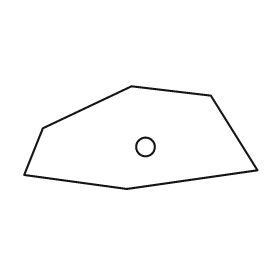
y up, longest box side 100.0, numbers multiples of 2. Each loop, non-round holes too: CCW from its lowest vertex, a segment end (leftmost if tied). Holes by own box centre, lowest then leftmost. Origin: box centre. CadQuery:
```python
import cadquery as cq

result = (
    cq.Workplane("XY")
    .moveTo(-6.0, -22.0)
    .lineTo(50.0, -14.0)
    .lineTo(30.0, 18.0)
    .lineTo(-4.0, 22.0)
    .lineTo(-42.0, 4.0)
    .lineTo(-50.0, -16.0)
    .close()
    .moveTo(2.0, -4.0)
    .circle(4.0)
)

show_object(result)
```